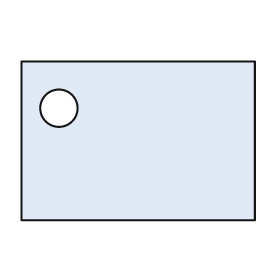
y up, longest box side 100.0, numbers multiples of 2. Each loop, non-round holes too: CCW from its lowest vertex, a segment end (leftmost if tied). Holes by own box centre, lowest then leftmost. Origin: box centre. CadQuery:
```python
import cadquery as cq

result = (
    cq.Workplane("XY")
    .moveTo(-50.0, -34.0)
    .lineTo(50.0, -34.0)
    .lineTo(50.0, 34.0)
    .lineTo(-50.0, 34.0)
    .close()
    .moveTo(-34.0, 14.0)
    .circle(8.0)
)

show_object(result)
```